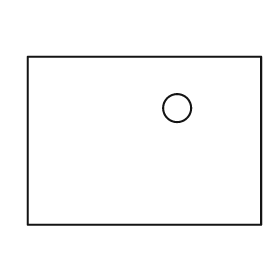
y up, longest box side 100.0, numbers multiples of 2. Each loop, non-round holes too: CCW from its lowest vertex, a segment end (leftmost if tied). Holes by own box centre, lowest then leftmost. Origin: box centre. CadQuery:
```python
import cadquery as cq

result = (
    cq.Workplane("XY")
    .moveTo(-50.0, -36.0)
    .lineTo(50.0, -36.0)
    .lineTo(50.0, 36.0)
    .lineTo(-50.0, 36.0)
    .close()
    .moveTo(14.0, 14.0)
    .circle(6.0)
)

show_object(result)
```